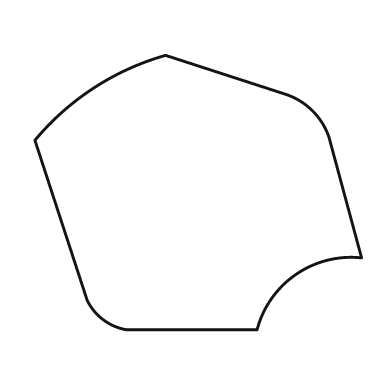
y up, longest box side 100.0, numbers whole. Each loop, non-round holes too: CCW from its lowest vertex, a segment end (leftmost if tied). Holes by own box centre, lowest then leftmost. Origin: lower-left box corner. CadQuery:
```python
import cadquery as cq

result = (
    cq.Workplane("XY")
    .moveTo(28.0, 0.0)
    .lineTo(68.0, 0.0)
    .threePointArc((80.0, 17.0), (100.0, 22.0))
    .lineTo(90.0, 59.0)
    .threePointArc((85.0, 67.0), (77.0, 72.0))
    .lineTo(40.0, 84.0)
    .threePointArc((18.0, 74.0), (0.0, 58.0))
    .lineTo(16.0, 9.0)
    .threePointArc((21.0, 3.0), (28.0, 0.0))
    .close()
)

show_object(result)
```